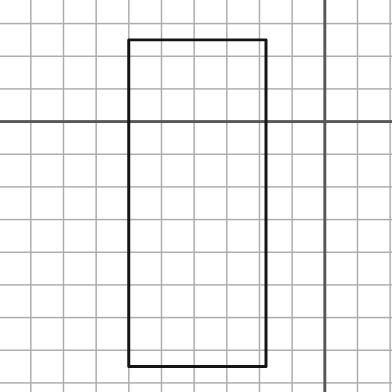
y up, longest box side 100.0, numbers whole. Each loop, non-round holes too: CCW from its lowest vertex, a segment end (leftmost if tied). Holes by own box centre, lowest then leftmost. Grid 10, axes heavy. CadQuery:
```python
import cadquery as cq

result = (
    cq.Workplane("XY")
    .moveTo(-60.0, -75.0)
    .lineTo(-18.0, -75.0)
    .lineTo(-18.0, 25.0)
    .lineTo(-60.0, 25.0)
    .close()
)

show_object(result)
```